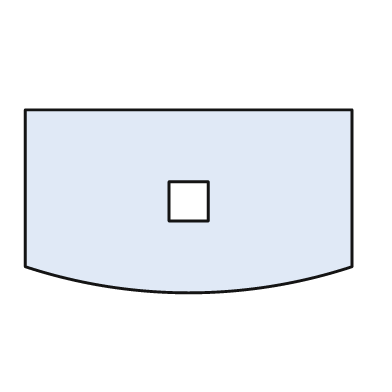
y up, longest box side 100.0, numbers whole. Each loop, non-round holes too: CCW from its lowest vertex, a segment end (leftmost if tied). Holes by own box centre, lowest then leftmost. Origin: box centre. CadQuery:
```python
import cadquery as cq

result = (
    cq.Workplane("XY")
    .moveTo(-50.0, -20.0)
    .threePointArc((0.0, -28.0), (50.0, -20.0))
    .lineTo(50.0, 28.0)
    .lineTo(-50.0, 28.0)
    .close()
    .moveTo(-6.0, -6.0)
    .lineTo(6.0, -6.0)
    .lineTo(6.0, 6.0)
    .lineTo(-6.0, 6.0)
    .close()
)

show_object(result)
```